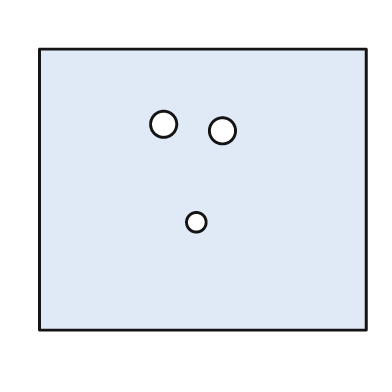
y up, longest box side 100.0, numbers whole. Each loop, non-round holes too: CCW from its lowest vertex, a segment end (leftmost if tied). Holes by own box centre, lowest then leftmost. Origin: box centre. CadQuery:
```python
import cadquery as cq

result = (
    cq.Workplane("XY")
    .moveTo(-50.0, -43.0)
    .lineTo(50.0, -43.0)
    .lineTo(50.0, 43.0)
    .lineTo(-50.0, 43.0)
    .close()
    .moveTo(-2.0, -10.0)
    .circle(3.0)
    .moveTo(6.0, 18.0)
    .circle(4.0)
    .moveTo(-12.0, 20.0)
    .circle(4.0)
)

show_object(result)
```